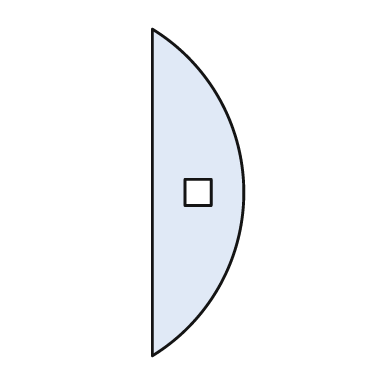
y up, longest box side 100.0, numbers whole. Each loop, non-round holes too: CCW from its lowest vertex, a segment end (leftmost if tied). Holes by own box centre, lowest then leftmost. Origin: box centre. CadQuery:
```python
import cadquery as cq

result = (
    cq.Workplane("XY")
    .moveTo(-14.0, -50.0)
    .threePointArc((14.0, 0.0), (-14.0, 50.0))
    .close()
    .moveTo(-4.0, -4.0)
    .lineTo(4.0, -4.0)
    .lineTo(4.0, 4.0)
    .lineTo(-4.0, 4.0)
    .close()
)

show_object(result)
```